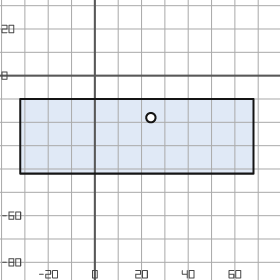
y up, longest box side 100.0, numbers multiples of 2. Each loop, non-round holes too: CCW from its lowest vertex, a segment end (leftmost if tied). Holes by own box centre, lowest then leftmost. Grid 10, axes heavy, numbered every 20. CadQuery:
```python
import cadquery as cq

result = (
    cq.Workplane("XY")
    .moveTo(-32.0, -42.0)
    .lineTo(68.0, -42.0)
    .lineTo(68.0, -10.0)
    .lineTo(-32.0, -10.0)
    .close()
    .moveTo(24.0, -18.0)
    .circle(2.0)
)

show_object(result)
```